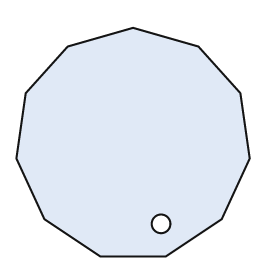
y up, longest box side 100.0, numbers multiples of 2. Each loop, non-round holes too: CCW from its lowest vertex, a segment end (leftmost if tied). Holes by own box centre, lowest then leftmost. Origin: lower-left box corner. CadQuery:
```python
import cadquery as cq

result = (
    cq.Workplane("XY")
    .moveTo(36.0, 0.0)
    .lineTo(64.0, 0.0)
    .lineTo(88.0, 16.0)
    .lineTo(100.0, 42.0)
    .lineTo(96.0, 70.0)
    .lineTo(78.0, 90.0)
    .lineTo(50.0, 98.0)
    .lineTo(22.0, 90.0)
    .lineTo(4.0, 70.0)
    .lineTo(0.0, 42.0)
    .lineTo(12.0, 16.0)
    .close()
    .moveTo(62.0, 14.0)
    .circle(4.0)
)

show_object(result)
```